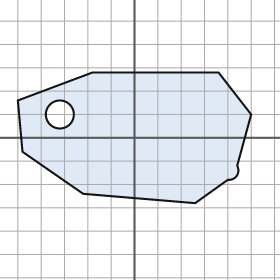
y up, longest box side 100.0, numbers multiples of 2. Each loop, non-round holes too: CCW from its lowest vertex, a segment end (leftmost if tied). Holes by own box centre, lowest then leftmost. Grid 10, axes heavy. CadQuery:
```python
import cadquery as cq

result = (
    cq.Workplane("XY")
    .moveTo(26.0, -28.0)
    .lineTo(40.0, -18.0)
    .threePointArc((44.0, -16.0), (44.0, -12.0))
    .lineTo(50.0, 10.0)
    .lineTo(36.0, 28.0)
    .lineTo(-18.0, 28.0)
    .lineTo(-50.0, 16.0)
    .lineTo(-48.0, -6.0)
    .lineTo(-22.0, -24.0)
    .close()
    .moveTo(-32.0, 10.0)
    .circle(6.0)
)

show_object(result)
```